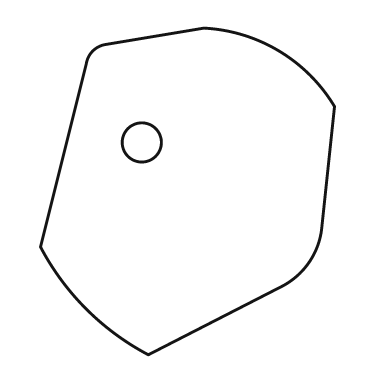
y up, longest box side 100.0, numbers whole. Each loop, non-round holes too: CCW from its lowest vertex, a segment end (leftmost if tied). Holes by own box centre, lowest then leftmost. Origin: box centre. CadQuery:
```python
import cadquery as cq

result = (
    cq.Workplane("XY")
    .moveTo(-12.0, -50.0)
    .lineTo(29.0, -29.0)
    .threePointArc((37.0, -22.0), (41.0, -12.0))
    .lineTo(45.0, 26.0)
    .threePointArc((28.0, 43.0), (5.0, 50.0))
    .lineTo(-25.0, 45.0)
    .threePointArc((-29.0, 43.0), (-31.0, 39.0))
    .lineTo(-45.0, -17.0)
    .threePointArc((-31.0, -36.0), (-12.0, -50.0))
    .close()
    .moveTo(-14.0, 15.0)
    .circle(6.0)
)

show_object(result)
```